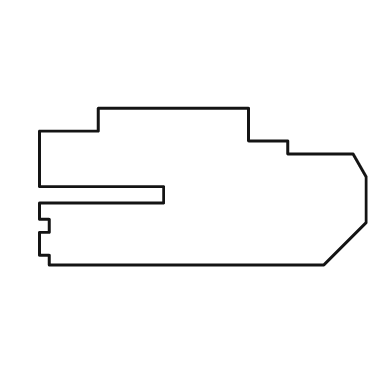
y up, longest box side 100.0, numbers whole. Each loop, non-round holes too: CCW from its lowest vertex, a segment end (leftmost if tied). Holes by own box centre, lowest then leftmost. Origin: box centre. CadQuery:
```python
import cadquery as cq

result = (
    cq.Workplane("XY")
    .moveTo(-47.0, -24.0)
    .lineTo(37.0, -24.0)
    .lineTo(50.0, -11.0)
    .lineTo(50.0, 3.0)
    .lineTo(46.0, 10.0)
    .lineTo(26.0, 10.0)
    .lineTo(26.0, 14.0)
    .lineTo(14.0, 14.0)
    .lineTo(14.0, 24.0)
    .lineTo(-32.0, 24.0)
    .lineTo(-32.0, 17.0)
    .lineTo(-50.0, 17.0)
    .lineTo(-50.0, 0.0)
    .lineTo(-12.0, 0.0)
    .lineTo(-12.0, -5.0)
    .lineTo(-50.0, -5.0)
    .lineTo(-50.0, -10.0)
    .lineTo(-47.0, -10.0)
    .lineTo(-47.0, -14.0)
    .lineTo(-50.0, -14.0)
    .lineTo(-50.0, -21.0)
    .lineTo(-47.0, -21.0)
    .close()
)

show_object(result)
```